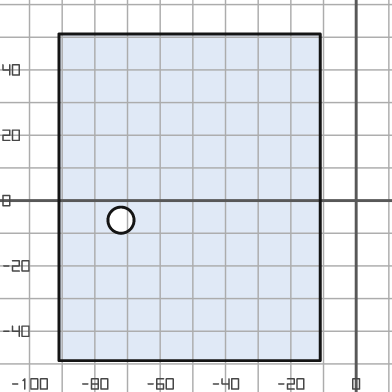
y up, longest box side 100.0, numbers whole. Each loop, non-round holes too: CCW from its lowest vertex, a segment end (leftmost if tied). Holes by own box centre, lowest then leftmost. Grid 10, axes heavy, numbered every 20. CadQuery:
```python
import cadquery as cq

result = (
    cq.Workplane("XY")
    .moveTo(-91.0, -49.0)
    .lineTo(-11.0, -49.0)
    .lineTo(-11.0, 51.0)
    .lineTo(-91.0, 51.0)
    .close()
    .moveTo(-72.0, -6.0)
    .circle(4.0)
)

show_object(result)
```